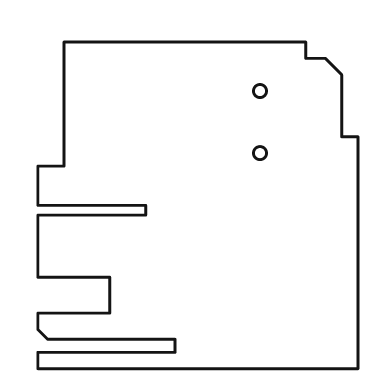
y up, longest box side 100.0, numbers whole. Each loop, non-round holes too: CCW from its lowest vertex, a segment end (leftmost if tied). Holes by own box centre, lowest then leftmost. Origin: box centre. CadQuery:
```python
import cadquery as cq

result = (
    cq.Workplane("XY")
    .moveTo(-49.0, -50.0)
    .lineTo(49.0, -50.0)
    .lineTo(49.0, 21.0)
    .lineTo(44.0, 21.0)
    .lineTo(44.0, 40.0)
    .lineTo(39.0, 45.0)
    .lineTo(33.0, 45.0)
    .lineTo(33.0, 50.0)
    .lineTo(-41.0, 50.0)
    .lineTo(-41.0, 12.0)
    .lineTo(-49.0, 12.0)
    .lineTo(-49.0, 0.0)
    .lineTo(-16.0, 0.0)
    .lineTo(-16.0, -3.0)
    .lineTo(-49.0, -3.0)
    .lineTo(-49.0, -22.0)
    .lineTo(-27.0, -22.0)
    .lineTo(-27.0, -33.0)
    .lineTo(-49.0, -33.0)
    .lineTo(-49.0, -38.0)
    .lineTo(-46.0, -41.0)
    .lineTo(-7.0, -41.0)
    .lineTo(-7.0, -45.0)
    .lineTo(-49.0, -45.0)
    .close()
    .moveTo(19.0, 16.0)
    .circle(2.0)
    .moveTo(19.0, 35.0)
    .circle(2.0)
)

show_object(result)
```